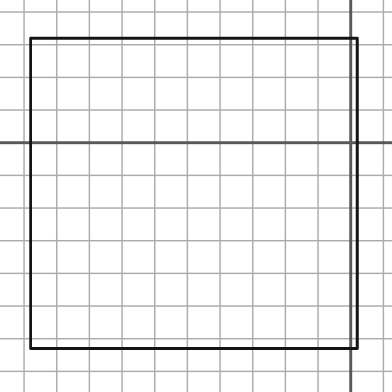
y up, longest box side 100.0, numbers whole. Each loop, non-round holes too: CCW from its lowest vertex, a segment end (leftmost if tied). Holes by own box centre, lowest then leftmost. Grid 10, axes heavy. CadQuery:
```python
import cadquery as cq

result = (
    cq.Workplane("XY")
    .moveTo(-98.0, -63.0)
    .lineTo(2.0, -63.0)
    .lineTo(2.0, 32.0)
    .lineTo(-98.0, 32.0)
    .close()
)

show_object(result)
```